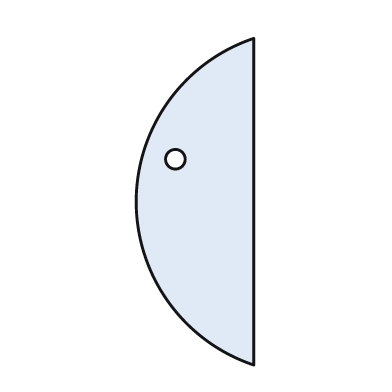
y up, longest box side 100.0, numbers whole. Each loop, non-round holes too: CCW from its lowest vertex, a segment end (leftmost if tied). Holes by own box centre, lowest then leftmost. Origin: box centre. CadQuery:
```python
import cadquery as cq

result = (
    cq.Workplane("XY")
    .moveTo(18.0, -50.0)
    .lineTo(18.0, 50.0)
    .threePointArc((-18.0, 0.0), (18.0, -50.0))
    .close()
    .moveTo(-6.0, 13.0)
    .circle(3.0)
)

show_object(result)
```